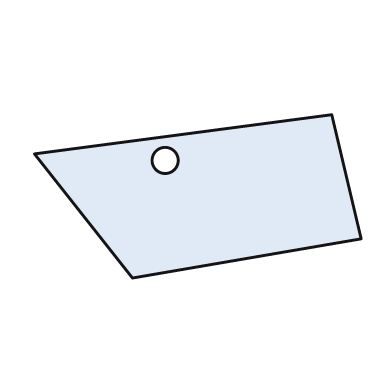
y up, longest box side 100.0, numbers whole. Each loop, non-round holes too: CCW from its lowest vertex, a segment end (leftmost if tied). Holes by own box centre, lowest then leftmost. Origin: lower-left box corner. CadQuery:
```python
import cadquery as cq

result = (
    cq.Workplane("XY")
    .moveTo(30.0, 0.0)
    .lineTo(100.0, 12.0)
    .lineTo(91.0, 50.0)
    .lineTo(0.0, 38.0)
    .close()
    .moveTo(40.0, 36.0)
    .circle(4.0)
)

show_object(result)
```